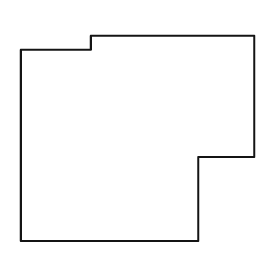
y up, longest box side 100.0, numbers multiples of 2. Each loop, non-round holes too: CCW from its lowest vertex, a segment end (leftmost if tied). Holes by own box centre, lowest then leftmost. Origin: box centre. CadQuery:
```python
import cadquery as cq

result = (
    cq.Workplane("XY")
    .moveTo(-50.0, -44.0)
    .lineTo(26.0, -44.0)
    .lineTo(26.0, -8.0)
    .lineTo(50.0, -8.0)
    .lineTo(50.0, 44.0)
    .lineTo(-20.0, 44.0)
    .lineTo(-20.0, 38.0)
    .lineTo(-50.0, 38.0)
    .close()
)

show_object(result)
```